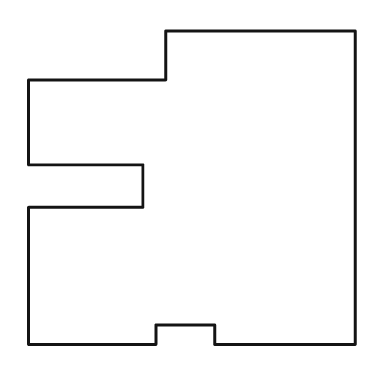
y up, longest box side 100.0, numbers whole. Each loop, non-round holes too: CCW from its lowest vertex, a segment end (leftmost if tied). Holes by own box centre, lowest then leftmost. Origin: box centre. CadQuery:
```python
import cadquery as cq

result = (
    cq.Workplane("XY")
    .moveTo(-50.0, -48.0)
    .lineTo(-11.0, -48.0)
    .lineTo(-11.0, -42.0)
    .lineTo(7.0, -42.0)
    .lineTo(7.0, -48.0)
    .lineTo(50.0, -48.0)
    .lineTo(50.0, 48.0)
    .lineTo(-8.0, 48.0)
    .lineTo(-8.0, 33.0)
    .lineTo(-50.0, 33.0)
    .lineTo(-50.0, 7.0)
    .lineTo(-15.0, 7.0)
    .lineTo(-15.0, -6.0)
    .lineTo(-50.0, -6.0)
    .close()
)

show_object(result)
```